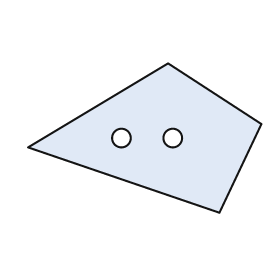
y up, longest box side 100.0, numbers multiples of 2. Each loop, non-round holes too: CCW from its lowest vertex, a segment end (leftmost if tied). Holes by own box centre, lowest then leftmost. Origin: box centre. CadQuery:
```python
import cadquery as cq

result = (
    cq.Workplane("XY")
    .moveTo(32.0, -32.0)
    .lineTo(50.0, 6.0)
    .lineTo(10.0, 32.0)
    .lineTo(-50.0, -4.0)
    .close()
    .moveTo(-10.0, 0.0)
    .circle(4.0)
    .moveTo(12.0, 0.0)
    .circle(4.0)
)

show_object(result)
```